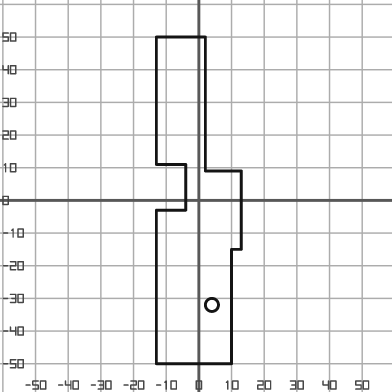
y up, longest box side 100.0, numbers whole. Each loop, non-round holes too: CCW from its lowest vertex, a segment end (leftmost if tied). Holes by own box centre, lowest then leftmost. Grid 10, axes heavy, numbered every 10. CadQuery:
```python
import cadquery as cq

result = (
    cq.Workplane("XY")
    .moveTo(-13.0, -50.0)
    .lineTo(10.0, -50.0)
    .lineTo(10.0, -15.0)
    .lineTo(13.0, -15.0)
    .lineTo(13.0, 9.0)
    .lineTo(2.0, 9.0)
    .lineTo(2.0, 50.0)
    .lineTo(-13.0, 50.0)
    .lineTo(-13.0, 11.0)
    .lineTo(-4.0, 11.0)
    .lineTo(-4.0, -3.0)
    .lineTo(-13.0, -3.0)
    .close()
    .moveTo(4.0, -32.0)
    .circle(2.0)
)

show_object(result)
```